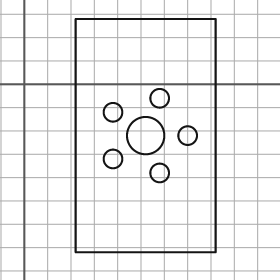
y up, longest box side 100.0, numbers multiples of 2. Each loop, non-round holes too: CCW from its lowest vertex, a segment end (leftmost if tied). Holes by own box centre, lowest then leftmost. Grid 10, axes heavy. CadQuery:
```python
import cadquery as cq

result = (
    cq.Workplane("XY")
    .moveTo(22.0, -72.0)
    .lineTo(82.0, -72.0)
    .lineTo(82.0, 28.0)
    .lineTo(22.0, 28.0)
    .close()
    .moveTo(58.0, -38.0)
    .circle(4.0)
    .moveTo(38.0, -32.0)
    .circle(4.0)
    .moveTo(52.0, -22.0)
    .circle(8.0)
    .moveTo(70.0, -22.0)
    .circle(4.0)
    .moveTo(38.0, -12.0)
    .circle(4.0)
    .moveTo(58.0, -6.0)
    .circle(4.0)
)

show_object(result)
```